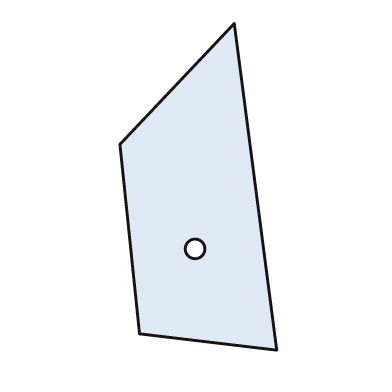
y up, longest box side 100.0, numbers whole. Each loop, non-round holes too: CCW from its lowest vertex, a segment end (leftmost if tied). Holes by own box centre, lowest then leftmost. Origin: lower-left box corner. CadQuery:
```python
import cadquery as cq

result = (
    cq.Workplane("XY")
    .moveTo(48.0, 0.0)
    .lineTo(35.0, 100.0)
    .lineTo(0.0, 63.0)
    .lineTo(6.0, 5.0)
    .close()
    .moveTo(23.0, 31.0)
    .circle(3.0)
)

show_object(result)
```